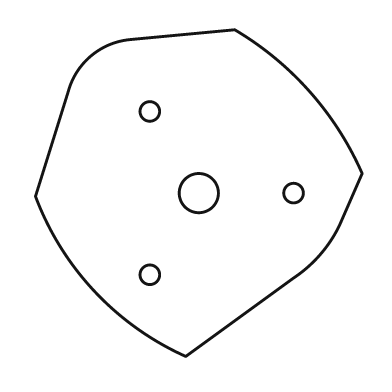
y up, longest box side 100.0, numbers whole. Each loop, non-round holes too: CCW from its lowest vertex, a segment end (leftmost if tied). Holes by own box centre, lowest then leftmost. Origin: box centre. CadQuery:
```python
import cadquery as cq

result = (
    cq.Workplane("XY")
    .moveTo(-4.0, -50.0)
    .lineTo(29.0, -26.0)
    .threePointArc((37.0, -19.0), (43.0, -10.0))
    .lineTo(50.0, 6.0)
    .threePointArc((34.0, 31.0), (11.0, 50.0))
    .lineTo(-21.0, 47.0)
    .threePointArc((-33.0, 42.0), (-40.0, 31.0))
    .lineTo(-50.0, -1.0)
    .threePointArc((-32.0, -30.0), (-4.0, -50.0))
    .close()
    .moveTo(-15.0, -25.0)
    .circle(3.0)
    .moveTo(0.0, 0.0)
    .circle(6.0)
    .moveTo(29.0, 0.0)
    .circle(3.0)
    .moveTo(-15.0, 25.0)
    .circle(3.0)
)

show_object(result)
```